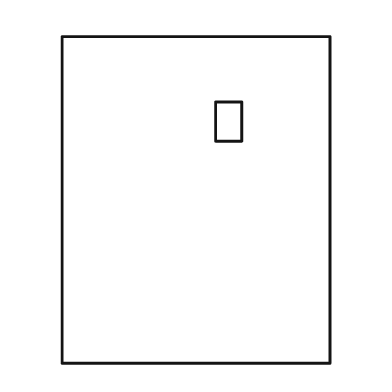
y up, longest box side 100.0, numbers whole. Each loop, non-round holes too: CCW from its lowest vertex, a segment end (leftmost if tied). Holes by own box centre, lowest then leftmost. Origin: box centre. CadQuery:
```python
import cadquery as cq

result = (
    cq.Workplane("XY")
    .moveTo(-41.0, -50.0)
    .lineTo(41.0, -50.0)
    .lineTo(41.0, 50.0)
    .lineTo(-41.0, 50.0)
    .close()
    .moveTo(6.0, 18.0)
    .lineTo(14.0, 18.0)
    .lineTo(14.0, 30.0)
    .lineTo(6.0, 30.0)
    .close()
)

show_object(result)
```